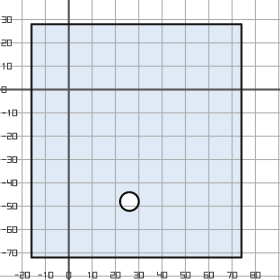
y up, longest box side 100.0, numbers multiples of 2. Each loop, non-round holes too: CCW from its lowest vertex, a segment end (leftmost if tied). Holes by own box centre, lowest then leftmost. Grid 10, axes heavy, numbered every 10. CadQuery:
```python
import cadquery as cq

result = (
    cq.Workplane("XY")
    .moveTo(-16.0, -72.0)
    .lineTo(74.0, -72.0)
    .lineTo(74.0, 28.0)
    .lineTo(-16.0, 28.0)
    .close()
    .moveTo(26.0, -48.0)
    .circle(4.0)
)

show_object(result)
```